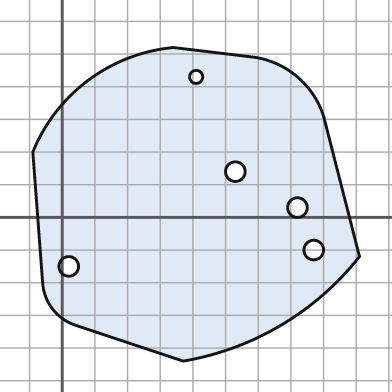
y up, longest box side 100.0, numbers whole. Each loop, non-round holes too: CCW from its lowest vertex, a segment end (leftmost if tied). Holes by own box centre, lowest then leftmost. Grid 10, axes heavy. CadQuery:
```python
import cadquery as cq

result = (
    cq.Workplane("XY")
    .moveTo(37.0, -44.0)
    .threePointArc((67.0, -33.0), (91.0, -12.0))
    .lineTo(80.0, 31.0)
    .threePointArc((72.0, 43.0), (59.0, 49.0))
    .lineTo(34.0, 52.0)
    .threePointArc((8.0, 42.0), (-9.0, 20.0))
    .lineTo(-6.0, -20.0)
    .threePointArc((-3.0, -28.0), (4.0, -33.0))
    .close()
    .moveTo(2.0, -15.0)
    .circle(3.0)
    .moveTo(77.0, -10.0)
    .circle(3.0)
    .moveTo(72.0, 3.0)
    .circle(3.0)
    .moveTo(53.0, 14.0)
    .circle(3.0)
    .moveTo(41.0, 43.0)
    .circle(2.0)
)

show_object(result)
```